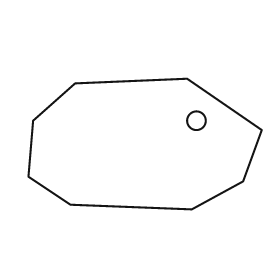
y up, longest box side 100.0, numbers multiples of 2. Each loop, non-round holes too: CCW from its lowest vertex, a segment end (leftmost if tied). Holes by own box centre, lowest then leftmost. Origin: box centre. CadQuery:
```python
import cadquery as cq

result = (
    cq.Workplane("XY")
    .moveTo(20.0, -28.0)
    .lineTo(42.0, -16.0)
    .lineTo(50.0, 6.0)
    .lineTo(18.0, 28.0)
    .lineTo(-30.0, 26.0)
    .lineTo(-48.0, 10.0)
    .lineTo(-50.0, -14.0)
    .lineTo(-32.0, -26.0)
    .close()
    .moveTo(22.0, 10.0)
    .circle(4.0)
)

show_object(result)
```